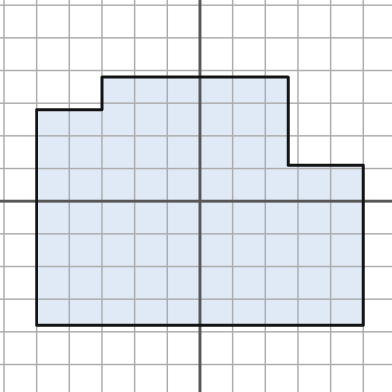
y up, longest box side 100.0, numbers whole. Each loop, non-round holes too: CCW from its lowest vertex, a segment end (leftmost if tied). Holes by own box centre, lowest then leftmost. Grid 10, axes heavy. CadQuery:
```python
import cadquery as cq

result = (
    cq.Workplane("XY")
    .moveTo(-50.0, -38.0)
    .lineTo(50.0, -38.0)
    .lineTo(50.0, 11.0)
    .lineTo(27.0, 11.0)
    .lineTo(27.0, 38.0)
    .lineTo(-30.0, 38.0)
    .lineTo(-30.0, 28.0)
    .lineTo(-50.0, 28.0)
    .close()
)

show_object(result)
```